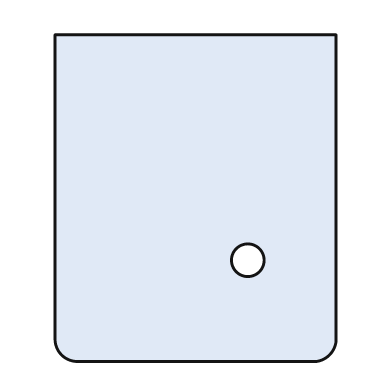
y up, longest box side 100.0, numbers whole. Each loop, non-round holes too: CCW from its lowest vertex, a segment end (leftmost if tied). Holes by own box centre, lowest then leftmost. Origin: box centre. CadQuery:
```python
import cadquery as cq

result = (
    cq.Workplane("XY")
    .moveTo(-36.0, -50.0)
    .lineTo(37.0, -50.0)
    .threePointArc((41.0, -48.0), (43.0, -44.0))
    .lineTo(43.0, 50.0)
    .lineTo(-43.0, 50.0)
    .lineTo(-43.0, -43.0)
    .threePointArc((-41.0, -48.0), (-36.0, -50.0))
    .close()
    .moveTo(16.0, -19.0)
    .circle(5.0)
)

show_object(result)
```